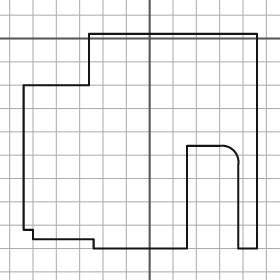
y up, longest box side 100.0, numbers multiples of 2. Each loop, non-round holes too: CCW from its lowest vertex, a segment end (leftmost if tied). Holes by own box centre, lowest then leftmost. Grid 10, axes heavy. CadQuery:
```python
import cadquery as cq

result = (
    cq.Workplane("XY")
    .moveTo(-24.0, -90.0)
    .lineTo(16.0, -90.0)
    .lineTo(16.0, -46.0)
    .lineTo(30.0, -46.0)
    .threePointArc((36.0, -48.0), (38.0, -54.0))
    .lineTo(38.0, -90.0)
    .lineTo(46.0, -90.0)
    .lineTo(46.0, 2.0)
    .lineTo(-26.0, 2.0)
    .lineTo(-26.0, -20.0)
    .lineTo(-54.0, -20.0)
    .lineTo(-54.0, -82.0)
    .lineTo(-50.0, -82.0)
    .lineTo(-50.0, -86.0)
    .lineTo(-24.0, -86.0)
    .close()
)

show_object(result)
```